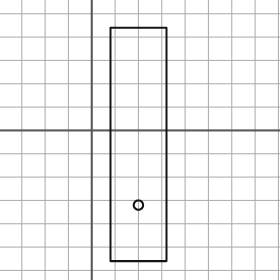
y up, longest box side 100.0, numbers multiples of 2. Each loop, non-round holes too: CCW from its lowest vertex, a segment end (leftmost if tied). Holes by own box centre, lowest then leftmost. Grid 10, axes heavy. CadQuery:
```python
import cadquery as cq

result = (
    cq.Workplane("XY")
    .moveTo(8.0, -56.0)
    .lineTo(32.0, -56.0)
    .lineTo(32.0, 44.0)
    .lineTo(8.0, 44.0)
    .close()
    .moveTo(20.0, -32.0)
    .circle(2.0)
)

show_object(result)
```